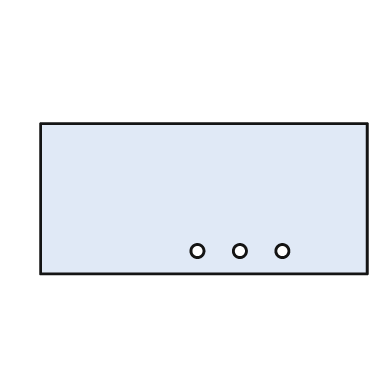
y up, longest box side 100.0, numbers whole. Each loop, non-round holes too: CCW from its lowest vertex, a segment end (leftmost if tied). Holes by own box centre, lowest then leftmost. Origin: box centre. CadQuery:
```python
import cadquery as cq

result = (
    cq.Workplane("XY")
    .moveTo(-50.0, -23.0)
    .lineTo(50.0, -23.0)
    .lineTo(50.0, 23.0)
    .lineTo(-50.0, 23.0)
    .close()
    .moveTo(-2.0, -16.0)
    .circle(2.0)
    .moveTo(11.0, -16.0)
    .circle(2.0)
    .moveTo(24.0, -16.0)
    .circle(2.0)
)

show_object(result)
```